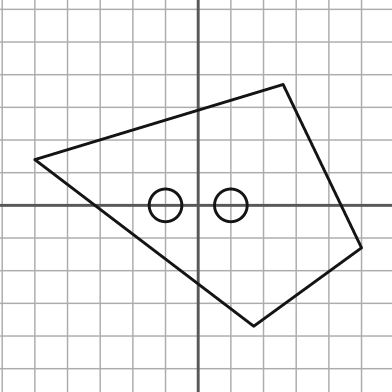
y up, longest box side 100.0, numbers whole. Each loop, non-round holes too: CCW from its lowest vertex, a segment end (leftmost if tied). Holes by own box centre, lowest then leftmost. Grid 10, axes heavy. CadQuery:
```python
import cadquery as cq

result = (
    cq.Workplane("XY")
    .moveTo(17.0, -37.0)
    .lineTo(50.0, -13.0)
    .lineTo(26.0, 37.0)
    .lineTo(-50.0, 14.0)
    .close()
    .moveTo(-10.0, 0.0)
    .circle(5.0)
    .moveTo(10.0, 0.0)
    .circle(5.0)
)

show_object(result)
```